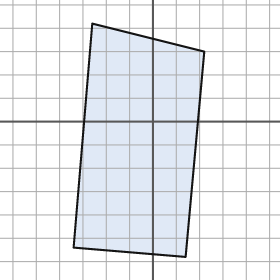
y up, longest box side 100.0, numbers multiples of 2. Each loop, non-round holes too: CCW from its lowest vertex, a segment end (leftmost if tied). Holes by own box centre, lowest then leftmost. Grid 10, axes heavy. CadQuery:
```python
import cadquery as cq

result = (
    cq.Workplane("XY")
    .moveTo(14.0, -58.0)
    .lineTo(22.0, 30.0)
    .lineTo(-26.0, 42.0)
    .lineTo(-34.0, -54.0)
    .close()
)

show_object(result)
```